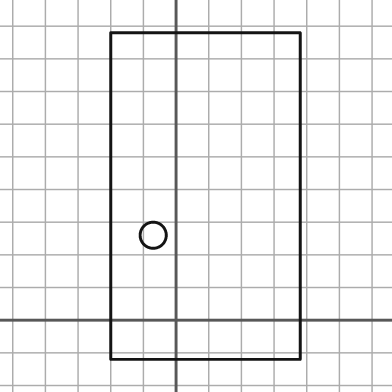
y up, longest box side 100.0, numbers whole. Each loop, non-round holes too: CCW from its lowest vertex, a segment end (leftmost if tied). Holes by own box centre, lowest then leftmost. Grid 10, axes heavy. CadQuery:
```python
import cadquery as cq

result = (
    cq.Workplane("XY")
    .moveTo(-20.0, -12.0)
    .lineTo(38.0, -12.0)
    .lineTo(38.0, 88.0)
    .lineTo(-20.0, 88.0)
    .close()
    .moveTo(-7.0, 26.0)
    .circle(4.0)
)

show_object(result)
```